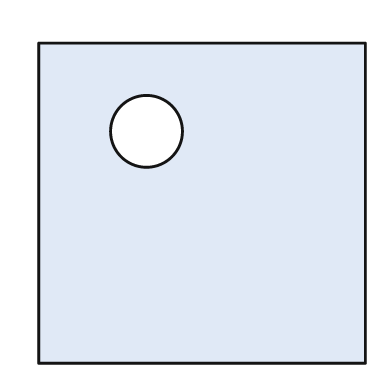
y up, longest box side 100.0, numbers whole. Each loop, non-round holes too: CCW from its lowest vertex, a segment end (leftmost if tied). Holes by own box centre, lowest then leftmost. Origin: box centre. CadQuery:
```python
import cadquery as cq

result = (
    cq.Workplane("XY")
    .moveTo(-50.0, -49.0)
    .lineTo(50.0, -49.0)
    .lineTo(50.0, 49.0)
    .lineTo(-50.0, 49.0)
    .close()
    .moveTo(-17.0, 22.0)
    .circle(11.0)
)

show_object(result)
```